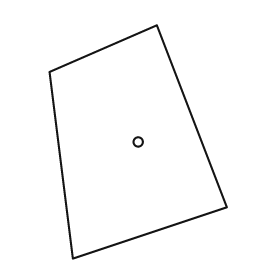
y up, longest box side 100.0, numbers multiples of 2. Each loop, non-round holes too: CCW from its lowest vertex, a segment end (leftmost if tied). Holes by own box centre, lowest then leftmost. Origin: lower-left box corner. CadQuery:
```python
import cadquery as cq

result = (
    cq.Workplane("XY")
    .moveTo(10.0, 0.0)
    .lineTo(76.0, 22.0)
    .lineTo(46.0, 100.0)
    .lineTo(0.0, 80.0)
    .close()
    .moveTo(38.0, 50.0)
    .circle(2.0)
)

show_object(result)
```